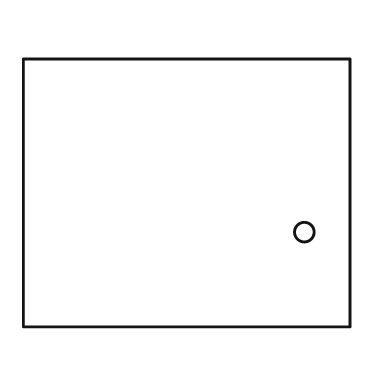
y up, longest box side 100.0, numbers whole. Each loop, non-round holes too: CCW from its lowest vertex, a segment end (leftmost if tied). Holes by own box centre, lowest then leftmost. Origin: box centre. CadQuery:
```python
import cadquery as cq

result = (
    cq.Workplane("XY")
    .moveTo(-50.0, -41.0)
    .lineTo(50.0, -41.0)
    .lineTo(50.0, 41.0)
    .lineTo(-50.0, 41.0)
    .close()
    .moveTo(36.0, -12.0)
    .circle(3.0)
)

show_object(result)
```